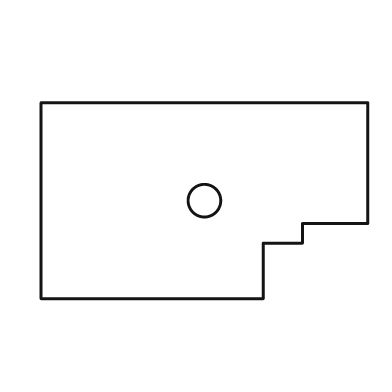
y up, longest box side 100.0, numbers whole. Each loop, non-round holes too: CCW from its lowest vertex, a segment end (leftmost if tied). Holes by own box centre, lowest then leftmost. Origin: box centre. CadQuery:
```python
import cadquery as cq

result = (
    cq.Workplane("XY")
    .moveTo(-50.0, -30.0)
    .lineTo(18.0, -30.0)
    .lineTo(18.0, -13.0)
    .lineTo(30.0, -13.0)
    .lineTo(30.0, -7.0)
    .lineTo(50.0, -7.0)
    .lineTo(50.0, 30.0)
    .lineTo(-50.0, 30.0)
    .close()
    .moveTo(0.0, 0.0)
    .circle(5.0)
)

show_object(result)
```